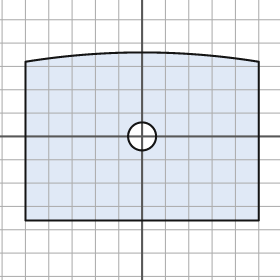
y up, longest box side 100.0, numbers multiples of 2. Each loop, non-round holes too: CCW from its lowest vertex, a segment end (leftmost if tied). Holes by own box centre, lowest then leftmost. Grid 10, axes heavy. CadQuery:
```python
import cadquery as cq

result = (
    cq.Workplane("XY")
    .moveTo(-50.0, -36.0)
    .lineTo(50.0, -36.0)
    .lineTo(50.0, 32.0)
    .threePointArc((0.0, 36.0), (-50.0, 32.0))
    .close()
    .moveTo(0.0, 0.0)
    .circle(6.0)
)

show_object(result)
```